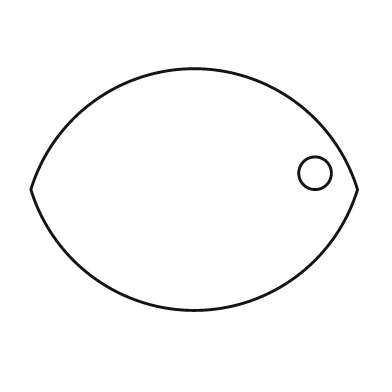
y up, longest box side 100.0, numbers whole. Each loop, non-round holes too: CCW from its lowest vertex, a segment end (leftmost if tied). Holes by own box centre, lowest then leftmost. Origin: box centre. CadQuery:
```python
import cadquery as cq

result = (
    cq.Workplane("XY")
    .moveTo(-50.0, 0.0)
    .threePointArc((0.0, -37.0), (50.0, 0.0))
    .threePointArc((0.0, 37.0), (-50.0, 0.0))
    .close()
    .moveTo(37.0, 5.0)
    .circle(5.0)
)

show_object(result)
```